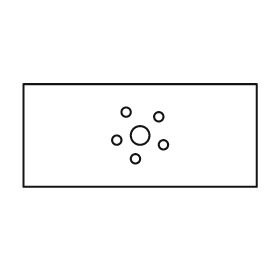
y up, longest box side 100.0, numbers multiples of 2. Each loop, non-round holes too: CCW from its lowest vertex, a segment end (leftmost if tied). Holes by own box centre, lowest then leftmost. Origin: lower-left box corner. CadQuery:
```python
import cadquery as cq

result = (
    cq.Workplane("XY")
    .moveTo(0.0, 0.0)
    .lineTo(100.0, 0.0)
    .lineTo(100.0, 44.0)
    .lineTo(0.0, 44.0)
    .close()
    .moveTo(48.0, 12.0)
    .circle(2.0)
    .moveTo(60.0, 18.0)
    .circle(2.0)
    .moveTo(40.0, 20.0)
    .circle(2.0)
    .moveTo(50.0, 22.0)
    .circle(4.0)
    .moveTo(58.0, 30.0)
    .circle(2.0)
    .moveTo(44.0, 32.0)
    .circle(2.0)
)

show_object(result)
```